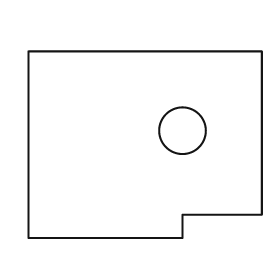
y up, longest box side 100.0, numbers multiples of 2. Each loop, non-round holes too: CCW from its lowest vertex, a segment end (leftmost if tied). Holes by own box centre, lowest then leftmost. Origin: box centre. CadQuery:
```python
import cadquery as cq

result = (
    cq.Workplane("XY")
    .moveTo(-50.0, -40.0)
    .lineTo(16.0, -40.0)
    .lineTo(16.0, -30.0)
    .lineTo(50.0, -30.0)
    .lineTo(50.0, 40.0)
    .lineTo(-50.0, 40.0)
    .close()
    .moveTo(16.0, 6.0)
    .circle(10.0)
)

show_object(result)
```